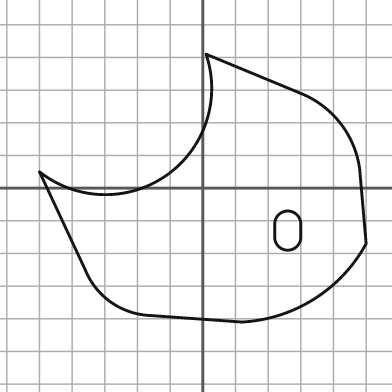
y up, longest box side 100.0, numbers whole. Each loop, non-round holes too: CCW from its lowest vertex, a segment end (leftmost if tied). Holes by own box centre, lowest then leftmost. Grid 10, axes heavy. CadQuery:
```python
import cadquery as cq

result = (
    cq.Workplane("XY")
    .moveTo(12.0, -41.0)
    .threePointArc((34.0, -34.0), (50.0, -17.0))
    .lineTo(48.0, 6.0)
    .threePointArc((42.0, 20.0), (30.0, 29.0))
    .lineTo(1.0, 41.0)
    .threePointArc((-11.0, 4.0), (-50.0, 5.0))
    .lineTo(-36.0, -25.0)
    .threePointArc((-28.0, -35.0), (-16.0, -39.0))
    .close()
    .moveTo(22.0, -15.0)
    .threePointArc((26.0, -19.0), (30.0, -15.0))
    .lineTo(30.0, -11.0)
    .threePointArc((26.0, -7.0), (22.0, -11.0))
    .close()
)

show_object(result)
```